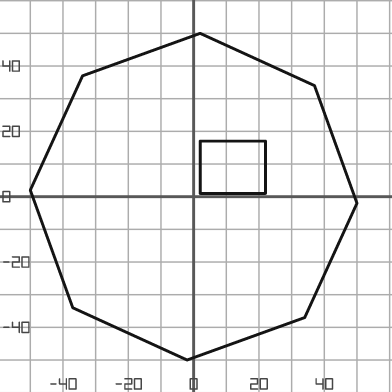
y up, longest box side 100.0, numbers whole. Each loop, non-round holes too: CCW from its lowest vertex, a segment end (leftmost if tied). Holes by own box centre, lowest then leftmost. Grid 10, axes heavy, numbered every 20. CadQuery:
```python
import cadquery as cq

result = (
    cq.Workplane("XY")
    .moveTo(-2.0, -50.0)
    .lineTo(34.0, -37.0)
    .lineTo(50.0, -2.0)
    .lineTo(37.0, 34.0)
    .lineTo(2.0, 50.0)
    .lineTo(-34.0, 37.0)
    .lineTo(-50.0, 2.0)
    .lineTo(-37.0, -34.0)
    .close()
    .moveTo(2.0, 1.0)
    .lineTo(22.0, 1.0)
    .lineTo(22.0, 17.0)
    .lineTo(2.0, 17.0)
    .close()
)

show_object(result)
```